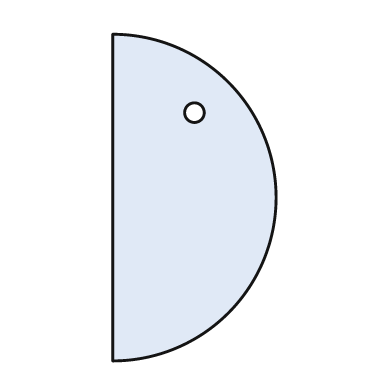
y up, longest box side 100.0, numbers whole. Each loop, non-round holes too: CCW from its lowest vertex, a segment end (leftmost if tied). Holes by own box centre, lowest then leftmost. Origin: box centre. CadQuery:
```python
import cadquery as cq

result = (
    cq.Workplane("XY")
    .moveTo(-25.0, -50.0)
    .threePointArc((25.0, 0.0), (-25.0, 50.0))
    .close()
    .moveTo(0.0, 26.0)
    .circle(3.0)
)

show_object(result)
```